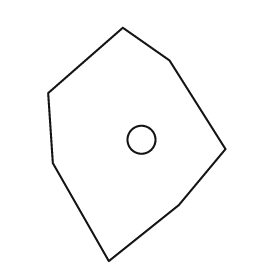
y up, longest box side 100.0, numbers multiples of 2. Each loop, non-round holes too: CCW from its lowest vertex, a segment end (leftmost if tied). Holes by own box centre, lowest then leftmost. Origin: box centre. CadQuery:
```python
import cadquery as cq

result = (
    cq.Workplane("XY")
    .moveTo(-12.0, -50.0)
    .lineTo(18.0, -26.0)
    .lineTo(38.0, -2.0)
    .lineTo(14.0, 36.0)
    .lineTo(-6.0, 50.0)
    .lineTo(-38.0, 22.0)
    .lineTo(-36.0, -8.0)
    .close()
    .moveTo(2.0, 2.0)
    .circle(6.0)
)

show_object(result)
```